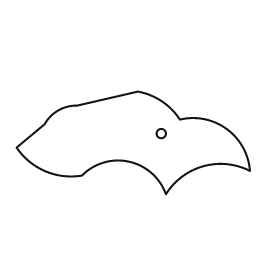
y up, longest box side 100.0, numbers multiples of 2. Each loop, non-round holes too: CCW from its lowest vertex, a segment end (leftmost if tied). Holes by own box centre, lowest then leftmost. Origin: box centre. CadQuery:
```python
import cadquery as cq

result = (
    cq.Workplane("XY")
    .moveTo(14.0, -22.0)
    .threePointArc((30.0, -10.0), (50.0, -12.0))
    .threePointArc((40.0, 6.0), (20.0, 10.0))
    .threePointArc((12.0, 18.0), (2.0, 22.0))
    .lineTo(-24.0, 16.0)
    .threePointArc((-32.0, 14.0), (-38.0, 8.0))
    .lineTo(-50.0, -2.0)
    .threePointArc((-38.0, -12.0), (-22.0, -14.0))
    .threePointArc((-2.0, -8.0), (14.0, -22.0))
    .close()
    .moveTo(12.0, 4.0)
    .circle(2.0)
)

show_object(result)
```